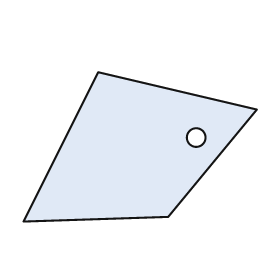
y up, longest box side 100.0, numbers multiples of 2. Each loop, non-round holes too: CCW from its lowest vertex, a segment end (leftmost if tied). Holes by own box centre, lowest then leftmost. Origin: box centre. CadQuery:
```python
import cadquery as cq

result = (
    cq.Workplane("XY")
    .moveTo(-50.0, -32.0)
    .lineTo(12.0, -30.0)
    .lineTo(50.0, 16.0)
    .lineTo(-18.0, 32.0)
    .close()
    .moveTo(24.0, 4.0)
    .circle(4.0)
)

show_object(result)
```